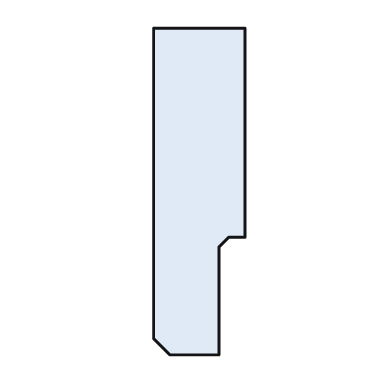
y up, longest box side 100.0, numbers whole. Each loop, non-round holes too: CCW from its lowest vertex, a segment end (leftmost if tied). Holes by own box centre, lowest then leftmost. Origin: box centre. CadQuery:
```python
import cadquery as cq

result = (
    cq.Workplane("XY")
    .moveTo(-9.0, -50.0)
    .lineTo(6.0, -50.0)
    .lineTo(6.0, -17.0)
    .lineTo(9.0, -14.0)
    .lineTo(14.0, -14.0)
    .lineTo(14.0, 50.0)
    .lineTo(-14.0, 50.0)
    .lineTo(-14.0, -45.0)
    .close()
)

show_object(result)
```